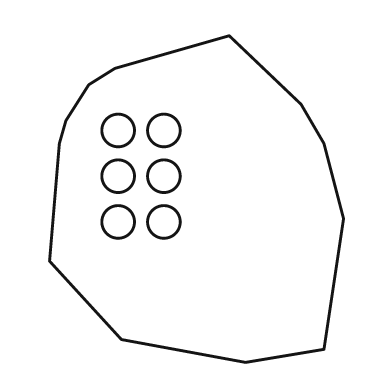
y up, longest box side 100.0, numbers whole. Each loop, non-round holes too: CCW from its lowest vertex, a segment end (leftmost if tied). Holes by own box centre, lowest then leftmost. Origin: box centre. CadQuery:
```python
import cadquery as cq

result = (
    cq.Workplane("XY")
    .moveTo(15.0, -50.0)
    .lineTo(39.0, -46.0)
    .lineTo(45.0, -6.0)
    .lineTo(39.0, 17.0)
    .lineTo(32.0, 29.0)
    .lineTo(10.0, 50.0)
    .lineTo(-25.0, 40.0)
    .lineTo(-33.0, 35.0)
    .lineTo(-40.0, 24.0)
    .lineTo(-42.0, 17.0)
    .lineTo(-45.0, -19.0)
    .lineTo(-23.0, -43.0)
    .close()
    .moveTo(-24.0, -7.0)
    .circle(5.0)
    .moveTo(-10.0, -7.0)
    .circle(5.0)
    .moveTo(-24.0, 7.0)
    .circle(5.0)
    .moveTo(-10.0, 7.0)
    .circle(5.0)
    .moveTo(-24.0, 21.0)
    .circle(5.0)
    .moveTo(-10.0, 21.0)
    .circle(5.0)
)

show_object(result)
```